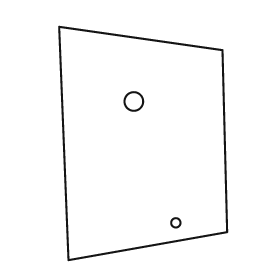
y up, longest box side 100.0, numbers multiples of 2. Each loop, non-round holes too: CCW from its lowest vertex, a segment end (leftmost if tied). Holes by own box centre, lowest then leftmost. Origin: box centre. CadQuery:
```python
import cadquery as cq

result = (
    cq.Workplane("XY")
    .moveTo(-32.0, -50.0)
    .lineTo(36.0, -38.0)
    .lineTo(34.0, 40.0)
    .lineTo(-36.0, 50.0)
    .close()
    .moveTo(14.0, -34.0)
    .circle(2.0)
    .moveTo(-4.0, 18.0)
    .circle(4.0)
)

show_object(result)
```